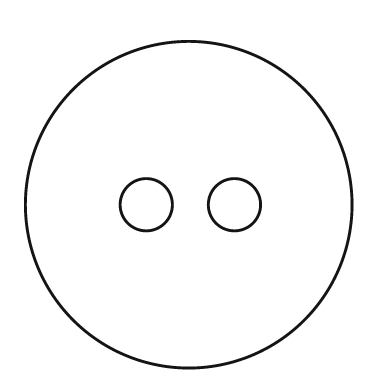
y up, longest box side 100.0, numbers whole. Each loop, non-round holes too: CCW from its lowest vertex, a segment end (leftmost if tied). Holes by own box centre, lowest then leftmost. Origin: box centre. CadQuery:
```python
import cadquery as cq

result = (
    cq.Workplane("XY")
    .moveTo(0.0, 0.0)
    .circle(50.0)
    .moveTo(-13.0, 0.0)
    .circle(8.0)
    .moveTo(14.0, 0.0)
    .circle(8.0)
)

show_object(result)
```